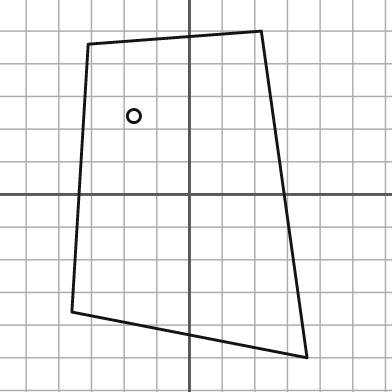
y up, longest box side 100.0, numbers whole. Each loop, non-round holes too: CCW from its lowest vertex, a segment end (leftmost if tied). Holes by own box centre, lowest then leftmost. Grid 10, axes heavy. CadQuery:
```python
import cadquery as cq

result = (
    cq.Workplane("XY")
    .moveTo(36.0, -50.0)
    .lineTo(22.0, 50.0)
    .lineTo(-31.0, 46.0)
    .lineTo(-36.0, -36.0)
    .close()
    .moveTo(-17.0, 24.0)
    .circle(2.0)
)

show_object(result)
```